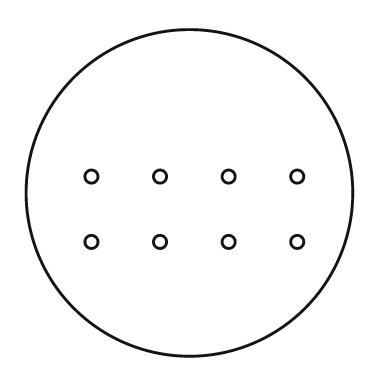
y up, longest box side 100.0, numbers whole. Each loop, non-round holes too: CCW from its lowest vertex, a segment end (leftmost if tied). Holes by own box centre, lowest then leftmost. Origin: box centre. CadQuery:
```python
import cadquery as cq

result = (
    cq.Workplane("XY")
    .moveTo(0.0, 0.0)
    .circle(50.0)
    .moveTo(-30.0, -15.0)
    .circle(2.0)
    .moveTo(-9.0, -15.0)
    .circle(2.0)
    .moveTo(12.0, -15.0)
    .circle(2.0)
    .moveTo(33.0, -15.0)
    .circle(2.0)
    .moveTo(-30.0, 5.0)
    .circle(2.0)
    .moveTo(-9.0, 5.0)
    .circle(2.0)
    .moveTo(12.0, 5.0)
    .circle(2.0)
    .moveTo(33.0, 5.0)
    .circle(2.0)
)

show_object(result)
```